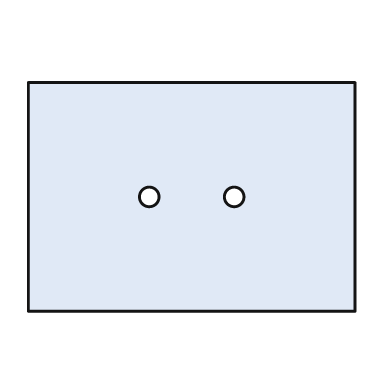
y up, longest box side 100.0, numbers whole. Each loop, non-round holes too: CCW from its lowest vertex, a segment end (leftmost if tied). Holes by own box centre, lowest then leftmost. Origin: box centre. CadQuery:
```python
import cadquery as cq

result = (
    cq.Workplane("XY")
    .moveTo(-50.0, -35.0)
    .lineTo(50.0, -35.0)
    .lineTo(50.0, 35.0)
    .lineTo(-50.0, 35.0)
    .close()
    .moveTo(-13.0, 0.0)
    .circle(3.0)
    .moveTo(13.0, 0.0)
    .circle(3.0)
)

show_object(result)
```